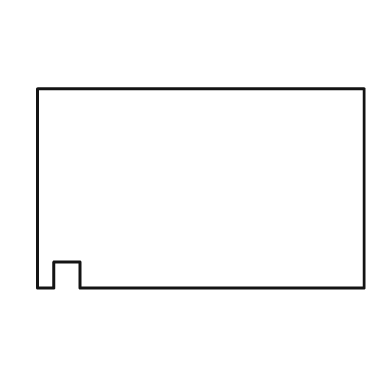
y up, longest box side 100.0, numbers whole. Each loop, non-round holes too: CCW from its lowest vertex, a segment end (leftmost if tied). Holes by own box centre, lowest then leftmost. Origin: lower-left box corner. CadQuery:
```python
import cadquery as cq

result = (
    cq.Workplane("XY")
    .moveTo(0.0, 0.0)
    .lineTo(5.0, 0.0)
    .lineTo(5.0, 8.0)
    .lineTo(13.0, 8.0)
    .lineTo(13.0, 0.0)
    .lineTo(100.0, 0.0)
    .lineTo(100.0, 61.0)
    .lineTo(0.0, 61.0)
    .close()
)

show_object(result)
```